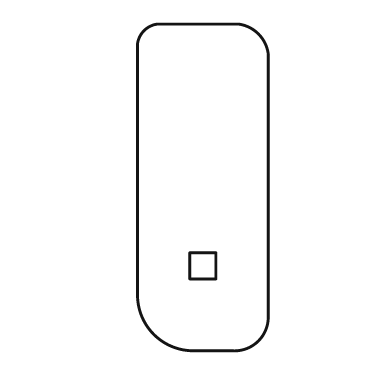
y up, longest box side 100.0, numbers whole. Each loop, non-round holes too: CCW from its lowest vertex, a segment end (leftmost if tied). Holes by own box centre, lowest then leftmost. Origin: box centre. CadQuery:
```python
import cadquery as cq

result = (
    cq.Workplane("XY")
    .moveTo(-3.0, -50.0)
    .lineTo(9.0, -50.0)
    .threePointArc((17.0, -47.0), (20.0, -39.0))
    .lineTo(20.0, 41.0)
    .threePointArc((17.0, 47.0), (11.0, 50.0))
    .lineTo(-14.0, 50.0)
    .threePointArc((-18.0, 48.0), (-20.0, 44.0))
    .lineTo(-20.0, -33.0)
    .threePointArc((-15.0, -45.0), (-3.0, -50.0))
    .close()
    .moveTo(-4.0, -28.0)
    .lineTo(4.0, -28.0)
    .lineTo(4.0, -20.0)
    .lineTo(-4.0, -20.0)
    .close()
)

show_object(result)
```